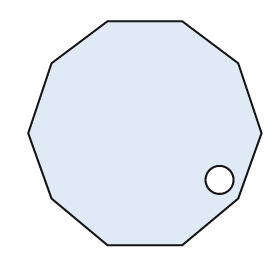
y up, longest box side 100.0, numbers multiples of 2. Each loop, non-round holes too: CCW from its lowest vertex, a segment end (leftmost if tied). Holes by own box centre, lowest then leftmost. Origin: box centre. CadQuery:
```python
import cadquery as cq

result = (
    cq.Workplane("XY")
    .moveTo(-16.0, -48.0)
    .lineTo(16.0, -48.0)
    .lineTo(40.0, -28.0)
    .lineTo(50.0, 0.0)
    .lineTo(40.0, 30.0)
    .lineTo(16.0, 48.0)
    .lineTo(-16.0, 48.0)
    .lineTo(-40.0, 30.0)
    .lineTo(-50.0, 0.0)
    .lineTo(-40.0, -28.0)
    .close()
    .moveTo(32.0, -20.0)
    .circle(6.0)
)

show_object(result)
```